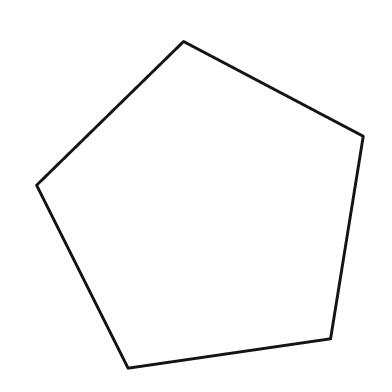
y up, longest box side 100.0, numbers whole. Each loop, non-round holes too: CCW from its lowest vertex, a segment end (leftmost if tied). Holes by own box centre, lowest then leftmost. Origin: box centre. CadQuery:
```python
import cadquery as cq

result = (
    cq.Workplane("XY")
    .moveTo(-22.0, -50.0)
    .lineTo(40.0, -41.0)
    .lineTo(50.0, 21.0)
    .lineTo(-5.0, 50.0)
    .lineTo(-50.0, 6.0)
    .close()
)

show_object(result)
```